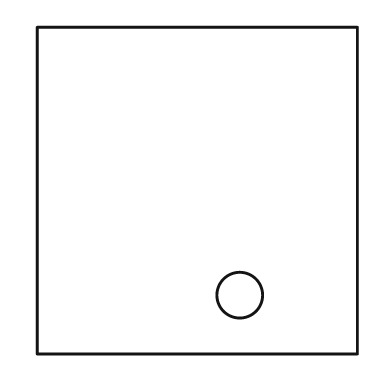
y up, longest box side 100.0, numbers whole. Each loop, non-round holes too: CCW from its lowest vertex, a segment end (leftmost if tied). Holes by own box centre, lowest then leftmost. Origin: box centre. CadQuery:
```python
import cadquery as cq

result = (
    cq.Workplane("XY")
    .moveTo(-49.0, -50.0)
    .lineTo(49.0, -50.0)
    .lineTo(49.0, 50.0)
    .lineTo(-49.0, 50.0)
    .close()
    .moveTo(13.0, -32.0)
    .circle(7.0)
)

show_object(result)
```